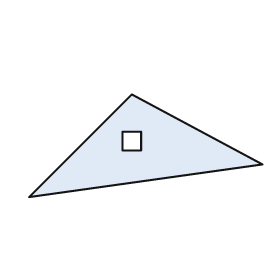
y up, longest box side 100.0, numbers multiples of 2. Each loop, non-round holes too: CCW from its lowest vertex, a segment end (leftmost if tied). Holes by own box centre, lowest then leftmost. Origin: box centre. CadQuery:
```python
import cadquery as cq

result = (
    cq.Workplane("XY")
    .moveTo(-50.0, -22.0)
    .lineTo(50.0, -8.0)
    .lineTo(-6.0, 22.0)
    .close()
    .moveTo(-10.0, -2.0)
    .lineTo(-2.0, -2.0)
    .lineTo(-2.0, 6.0)
    .lineTo(-10.0, 6.0)
    .close()
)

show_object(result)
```